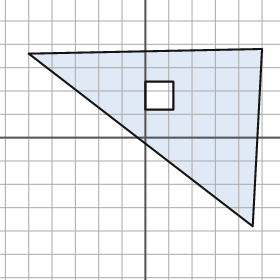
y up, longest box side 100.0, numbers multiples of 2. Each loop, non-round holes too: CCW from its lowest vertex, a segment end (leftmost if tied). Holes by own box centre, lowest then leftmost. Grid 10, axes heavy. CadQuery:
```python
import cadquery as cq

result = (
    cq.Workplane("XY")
    .moveTo(46.0, -38.0)
    .lineTo(50.0, 38.0)
    .lineTo(-50.0, 36.0)
    .close()
    .moveTo(0.0, 12.0)
    .lineTo(12.0, 12.0)
    .lineTo(12.0, 24.0)
    .lineTo(0.0, 24.0)
    .close()
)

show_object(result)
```